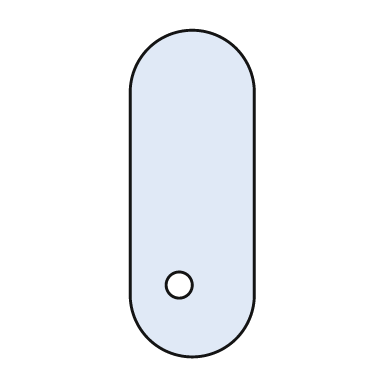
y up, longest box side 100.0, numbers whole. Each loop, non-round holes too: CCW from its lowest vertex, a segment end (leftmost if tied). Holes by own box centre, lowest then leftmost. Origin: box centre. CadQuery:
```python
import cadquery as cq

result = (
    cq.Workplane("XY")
    .moveTo(-19.0, -31.0)
    .threePointArc((0.0, -50.0), (19.0, -31.0))
    .lineTo(19.0, 31.0)
    .threePointArc((0.0, 50.0), (-19.0, 31.0))
    .close()
    .moveTo(-4.0, -28.0)
    .circle(4.0)
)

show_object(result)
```